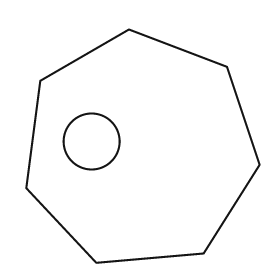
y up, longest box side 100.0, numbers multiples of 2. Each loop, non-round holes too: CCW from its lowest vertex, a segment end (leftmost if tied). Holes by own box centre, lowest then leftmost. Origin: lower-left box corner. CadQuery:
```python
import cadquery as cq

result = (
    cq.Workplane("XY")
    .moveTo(30.0, 0.0)
    .lineTo(76.0, 4.0)
    .lineTo(100.0, 42.0)
    .lineTo(86.0, 84.0)
    .lineTo(44.0, 100.0)
    .lineTo(6.0, 78.0)
    .lineTo(0.0, 32.0)
    .close()
    .moveTo(28.0, 52.0)
    .circle(12.0)
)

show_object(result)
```